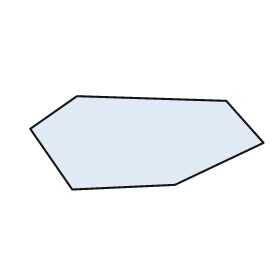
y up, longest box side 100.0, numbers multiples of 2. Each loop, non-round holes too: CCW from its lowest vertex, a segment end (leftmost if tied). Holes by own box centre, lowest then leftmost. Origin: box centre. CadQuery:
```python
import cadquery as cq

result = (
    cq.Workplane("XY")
    .moveTo(-32.0, -20.0)
    .lineTo(12.0, -18.0)
    .lineTo(50.0, 0.0)
    .lineTo(34.0, 18.0)
    .lineTo(-30.0, 20.0)
    .lineTo(-50.0, 6.0)
    .close()
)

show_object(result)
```